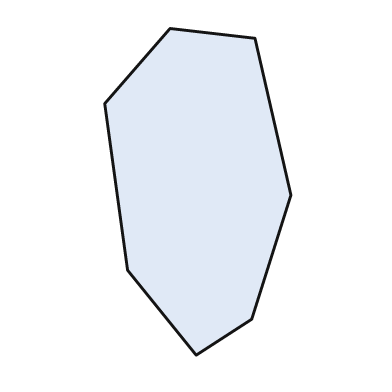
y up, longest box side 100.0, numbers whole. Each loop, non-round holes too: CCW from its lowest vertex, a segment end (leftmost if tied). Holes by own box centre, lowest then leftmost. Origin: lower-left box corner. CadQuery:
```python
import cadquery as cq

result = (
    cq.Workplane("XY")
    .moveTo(28.0, 0.0)
    .lineTo(45.0, 11.0)
    .lineTo(57.0, 49.0)
    .lineTo(46.0, 97.0)
    .lineTo(20.0, 100.0)
    .lineTo(0.0, 77.0)
    .lineTo(7.0, 26.0)
    .close()
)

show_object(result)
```